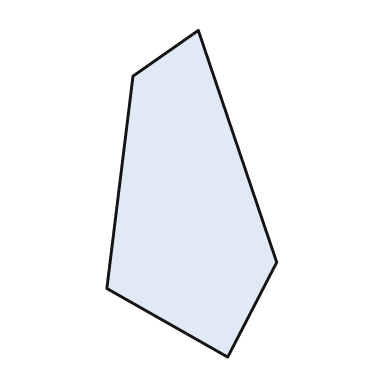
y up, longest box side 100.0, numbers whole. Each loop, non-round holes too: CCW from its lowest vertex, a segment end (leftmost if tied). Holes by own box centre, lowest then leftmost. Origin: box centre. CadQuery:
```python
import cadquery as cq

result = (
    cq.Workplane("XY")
    .moveTo(11.0, -50.0)
    .lineTo(26.0, -21.0)
    .lineTo(2.0, 50.0)
    .lineTo(-18.0, 36.0)
    .lineTo(-26.0, -29.0)
    .close()
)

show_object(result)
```